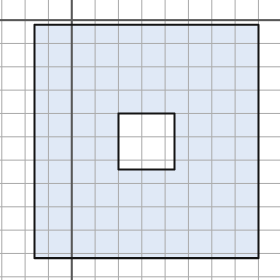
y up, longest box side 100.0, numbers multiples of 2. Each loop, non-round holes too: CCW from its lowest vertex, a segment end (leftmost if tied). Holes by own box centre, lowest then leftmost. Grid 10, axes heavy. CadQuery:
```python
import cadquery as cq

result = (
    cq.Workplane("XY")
    .moveTo(-16.0, -102.0)
    .lineTo(80.0, -102.0)
    .lineTo(80.0, -2.0)
    .lineTo(-16.0, -2.0)
    .close()
    .moveTo(20.0, -64.0)
    .lineTo(44.0, -64.0)
    .lineTo(44.0, -40.0)
    .lineTo(20.0, -40.0)
    .close()
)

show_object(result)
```